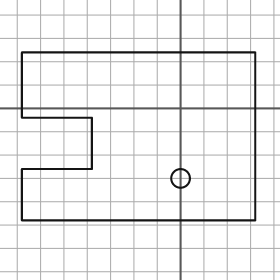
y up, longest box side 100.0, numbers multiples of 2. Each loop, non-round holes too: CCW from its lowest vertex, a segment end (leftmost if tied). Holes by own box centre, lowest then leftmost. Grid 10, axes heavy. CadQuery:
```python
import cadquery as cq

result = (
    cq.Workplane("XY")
    .moveTo(-68.0, -48.0)
    .lineTo(32.0, -48.0)
    .lineTo(32.0, 24.0)
    .lineTo(-68.0, 24.0)
    .lineTo(-68.0, -4.0)
    .lineTo(-38.0, -4.0)
    .lineTo(-38.0, -26.0)
    .lineTo(-68.0, -26.0)
    .close()
    .moveTo(0.0, -30.0)
    .circle(4.0)
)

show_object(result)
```